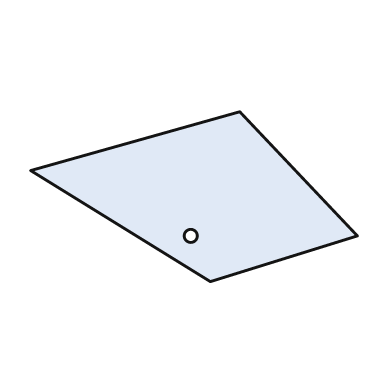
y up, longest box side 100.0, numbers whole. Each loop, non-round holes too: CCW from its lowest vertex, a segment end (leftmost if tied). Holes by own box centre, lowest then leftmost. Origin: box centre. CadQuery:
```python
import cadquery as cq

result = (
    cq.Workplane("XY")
    .moveTo(5.0, -26.0)
    .lineTo(50.0, -12.0)
    .lineTo(14.0, 26.0)
    .lineTo(-50.0, 8.0)
    .close()
    .moveTo(-1.0, -12.0)
    .circle(2.0)
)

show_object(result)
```